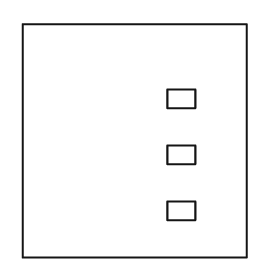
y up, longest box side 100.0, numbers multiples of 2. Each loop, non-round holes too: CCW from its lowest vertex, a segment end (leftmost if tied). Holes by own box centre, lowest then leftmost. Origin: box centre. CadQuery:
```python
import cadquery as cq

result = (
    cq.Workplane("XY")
    .moveTo(-48.0, -50.0)
    .lineTo(48.0, -50.0)
    .lineTo(48.0, 50.0)
    .lineTo(-48.0, 50.0)
    .close()
    .moveTo(14.0, -34.0)
    .lineTo(26.0, -34.0)
    .lineTo(26.0, -26.0)
    .lineTo(14.0, -26.0)
    .close()
    .moveTo(14.0, -10.0)
    .lineTo(26.0, -10.0)
    .lineTo(26.0, -2.0)
    .lineTo(14.0, -2.0)
    .close()
    .moveTo(14.0, 14.0)
    .lineTo(26.0, 14.0)
    .lineTo(26.0, 22.0)
    .lineTo(14.0, 22.0)
    .close()
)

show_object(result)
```